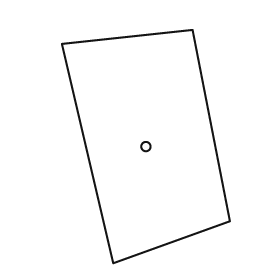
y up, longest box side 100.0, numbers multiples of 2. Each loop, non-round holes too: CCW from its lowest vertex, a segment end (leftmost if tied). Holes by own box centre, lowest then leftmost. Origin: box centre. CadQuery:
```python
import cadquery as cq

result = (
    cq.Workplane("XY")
    .moveTo(-14.0, -50.0)
    .lineTo(36.0, -32.0)
    .lineTo(20.0, 50.0)
    .lineTo(-36.0, 44.0)
    .close()
    .moveTo(0.0, 0.0)
    .circle(2.0)
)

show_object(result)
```